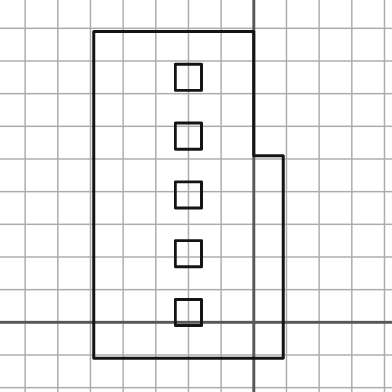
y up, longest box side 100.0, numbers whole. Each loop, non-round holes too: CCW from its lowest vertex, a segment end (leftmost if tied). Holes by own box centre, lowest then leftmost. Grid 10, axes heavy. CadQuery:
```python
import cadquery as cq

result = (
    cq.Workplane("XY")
    .moveTo(-49.0, -11.0)
    .lineTo(9.0, -11.0)
    .lineTo(9.0, 51.0)
    .lineTo(0.0, 51.0)
    .lineTo(0.0, 89.0)
    .lineTo(-49.0, 89.0)
    .close()
    .moveTo(-24.0, -1.0)
    .lineTo(-16.0, -1.0)
    .lineTo(-16.0, 7.0)
    .lineTo(-24.0, 7.0)
    .close()
    .moveTo(-24.0, 17.0)
    .lineTo(-16.0, 17.0)
    .lineTo(-16.0, 25.0)
    .lineTo(-24.0, 25.0)
    .close()
    .moveTo(-24.0, 35.0)
    .lineTo(-16.0, 35.0)
    .lineTo(-16.0, 43.0)
    .lineTo(-24.0, 43.0)
    .close()
    .moveTo(-24.0, 53.0)
    .lineTo(-16.0, 53.0)
    .lineTo(-16.0, 61.0)
    .lineTo(-24.0, 61.0)
    .close()
    .moveTo(-24.0, 71.0)
    .lineTo(-16.0, 71.0)
    .lineTo(-16.0, 79.0)
    .lineTo(-24.0, 79.0)
    .close()
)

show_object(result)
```